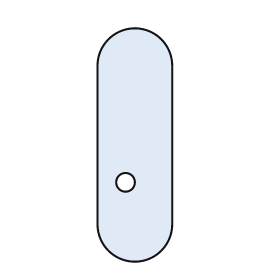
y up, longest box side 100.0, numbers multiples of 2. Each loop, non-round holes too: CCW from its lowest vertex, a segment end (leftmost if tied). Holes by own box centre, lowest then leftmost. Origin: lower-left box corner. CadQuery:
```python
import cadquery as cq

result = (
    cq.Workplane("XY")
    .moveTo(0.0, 16.0)
    .threePointArc((16.0, 0.0), (32.0, 16.0))
    .lineTo(32.0, 84.0)
    .threePointArc((16.0, 100.0), (0.0, 84.0))
    .close()
    .moveTo(12.0, 34.0)
    .circle(4.0)
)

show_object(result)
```